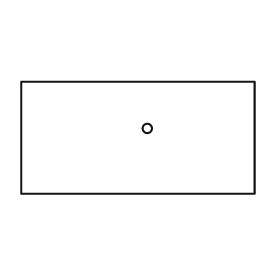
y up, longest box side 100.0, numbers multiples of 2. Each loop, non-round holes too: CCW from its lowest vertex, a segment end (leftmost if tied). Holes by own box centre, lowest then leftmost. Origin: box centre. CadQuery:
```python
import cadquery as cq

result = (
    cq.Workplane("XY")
    .moveTo(-50.0, -24.0)
    .lineTo(50.0, -24.0)
    .lineTo(50.0, 24.0)
    .lineTo(-50.0, 24.0)
    .close()
    .moveTo(4.0, 4.0)
    .circle(2.0)
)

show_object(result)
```